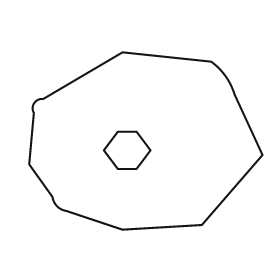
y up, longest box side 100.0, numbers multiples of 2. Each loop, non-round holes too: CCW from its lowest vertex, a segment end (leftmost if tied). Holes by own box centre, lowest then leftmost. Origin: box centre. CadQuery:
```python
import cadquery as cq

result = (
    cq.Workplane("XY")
    .moveTo(-10.0, -38.0)
    .lineTo(24.0, -36.0)
    .lineTo(50.0, -6.0)
    .lineTo(38.0, 20.0)
    .threePointArc((34.0, 28.0), (28.0, 34.0))
    .lineTo(-10.0, 38.0)
    .lineTo(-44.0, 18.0)
    .threePointArc((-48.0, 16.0), (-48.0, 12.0))
    .lineTo(-50.0, -10.0)
    .lineTo(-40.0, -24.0)
    .threePointArc((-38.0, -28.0), (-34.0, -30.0))
    .close()
    .moveTo(-12.0, -12.0)
    .lineTo(-4.0, -12.0)
    .lineTo(2.0, -4.0)
    .lineTo(-4.0, 4.0)
    .lineTo(-12.0, 4.0)
    .lineTo(-18.0, -4.0)
    .close()
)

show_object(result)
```